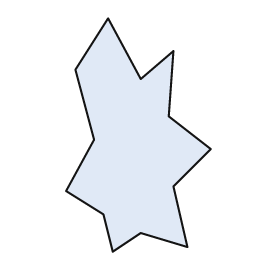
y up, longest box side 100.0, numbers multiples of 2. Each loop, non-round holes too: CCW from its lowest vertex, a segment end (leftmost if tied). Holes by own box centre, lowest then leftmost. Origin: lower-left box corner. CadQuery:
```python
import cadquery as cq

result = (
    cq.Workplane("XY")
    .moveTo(20.0, 0.0)
    .lineTo(32.0, 8.0)
    .lineTo(52.0, 2.0)
    .lineTo(46.0, 28.0)
    .lineTo(62.0, 44.0)
    .lineTo(44.0, 58.0)
    .lineTo(46.0, 86.0)
    .lineTo(32.0, 74.0)
    .lineTo(18.0, 100.0)
    .lineTo(4.0, 78.0)
    .lineTo(12.0, 48.0)
    .lineTo(0.0, 26.0)
    .lineTo(16.0, 16.0)
    .close()
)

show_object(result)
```